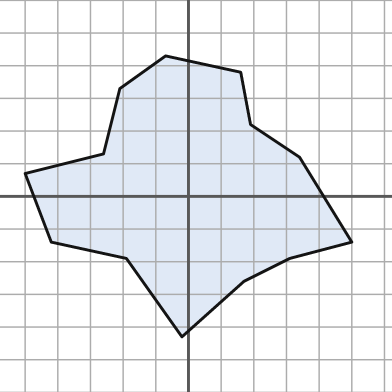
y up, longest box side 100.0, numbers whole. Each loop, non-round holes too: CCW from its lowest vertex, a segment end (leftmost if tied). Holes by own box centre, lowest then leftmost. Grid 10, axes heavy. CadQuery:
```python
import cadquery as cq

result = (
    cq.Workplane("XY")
    .moveTo(-2.0, -43.0)
    .lineTo(17.0, -26.0)
    .lineTo(31.0, -19.0)
    .lineTo(50.0, -14.0)
    .lineTo(34.0, 12.0)
    .lineTo(19.0, 22.0)
    .lineTo(16.0, 38.0)
    .lineTo(-7.0, 43.0)
    .lineTo(-21.0, 33.0)
    .lineTo(-26.0, 13.0)
    .lineTo(-50.0, 7.0)
    .lineTo(-42.0, -14.0)
    .lineTo(-19.0, -19.0)
    .close()
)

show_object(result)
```